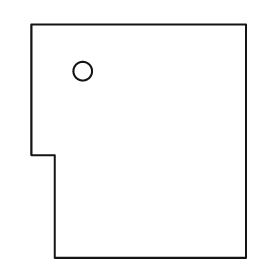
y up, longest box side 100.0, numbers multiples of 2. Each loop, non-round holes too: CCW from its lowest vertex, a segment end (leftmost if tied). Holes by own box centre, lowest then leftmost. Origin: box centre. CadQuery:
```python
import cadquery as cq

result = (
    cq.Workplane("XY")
    .moveTo(-36.0, -50.0)
    .lineTo(46.0, -50.0)
    .lineTo(46.0, 50.0)
    .lineTo(-46.0, 50.0)
    .lineTo(-46.0, -6.0)
    .lineTo(-36.0, -6.0)
    .close()
    .moveTo(-24.0, 30.0)
    .circle(4.0)
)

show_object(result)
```